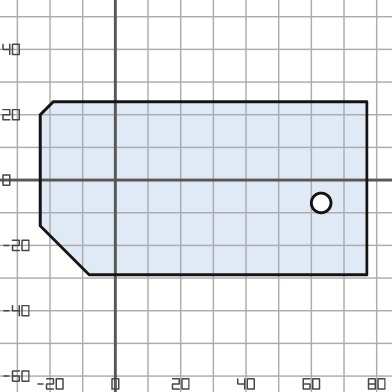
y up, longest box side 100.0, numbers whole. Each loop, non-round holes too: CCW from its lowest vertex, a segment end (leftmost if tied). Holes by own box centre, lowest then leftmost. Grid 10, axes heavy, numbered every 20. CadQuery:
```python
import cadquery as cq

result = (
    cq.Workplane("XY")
    .moveTo(-8.0, -29.0)
    .lineTo(77.0, -29.0)
    .lineTo(77.0, 24.0)
    .lineTo(-19.0, 24.0)
    .lineTo(-23.0, 20.0)
    .lineTo(-23.0, -14.0)
    .close()
    .moveTo(63.0, -7.0)
    .circle(3.0)
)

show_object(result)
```